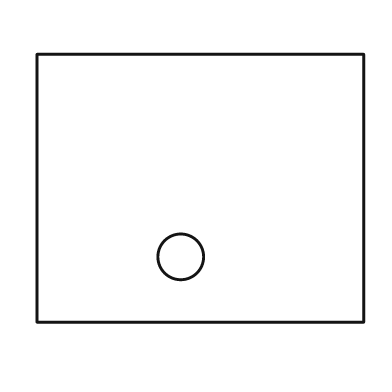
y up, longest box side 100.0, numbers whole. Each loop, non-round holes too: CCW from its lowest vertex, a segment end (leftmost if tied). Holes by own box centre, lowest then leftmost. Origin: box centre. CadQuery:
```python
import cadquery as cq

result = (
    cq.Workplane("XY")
    .moveTo(-50.0, -41.0)
    .lineTo(50.0, -41.0)
    .lineTo(50.0, 41.0)
    .lineTo(-50.0, 41.0)
    .close()
    .moveTo(-6.0, -21.0)
    .circle(7.0)
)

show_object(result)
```